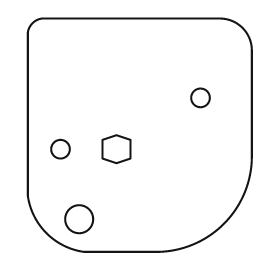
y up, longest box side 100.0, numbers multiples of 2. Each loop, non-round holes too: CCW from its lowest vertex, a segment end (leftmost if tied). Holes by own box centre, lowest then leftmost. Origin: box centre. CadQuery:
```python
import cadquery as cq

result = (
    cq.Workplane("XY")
    .moveTo(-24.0, -50.0)
    .lineTo(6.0, -50.0)
    .threePointArc((36.0, -38.0), (48.0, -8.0))
    .lineTo(48.0, 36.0)
    .threePointArc((44.0, 46.0), (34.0, 50.0))
    .lineTo(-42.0, 50.0)
    .threePointArc((-46.0, 48.0), (-48.0, 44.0))
    .lineTo(-48.0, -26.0)
    .threePointArc((-40.0, -42.0), (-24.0, -50.0))
    .close()
    .moveTo(-26.0, -36.0)
    .circle(6.0)
    .moveTo(-34.0, -6.0)
    .circle(4.0)
    .moveTo(-10.0, -12.0)
    .lineTo(-4.0, -10.0)
    .lineTo(-4.0, -2.0)
    .lineTo(-10.0, 0.0)
    .lineTo(-16.0, -2.0)
    .lineTo(-16.0, -10.0)
    .close()
    .moveTo(26.0, 16.0)
    .circle(4.0)
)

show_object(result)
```